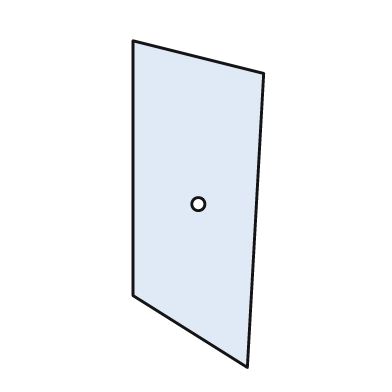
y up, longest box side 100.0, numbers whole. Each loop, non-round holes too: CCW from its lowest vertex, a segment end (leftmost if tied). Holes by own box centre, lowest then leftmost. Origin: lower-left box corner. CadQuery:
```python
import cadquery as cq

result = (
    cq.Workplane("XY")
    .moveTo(35.0, 0.0)
    .lineTo(40.0, 90.0)
    .lineTo(0.0, 100.0)
    .lineTo(0.0, 22.0)
    .close()
    .moveTo(20.0, 50.0)
    .circle(2.0)
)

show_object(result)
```